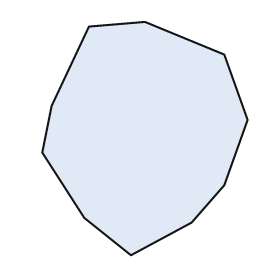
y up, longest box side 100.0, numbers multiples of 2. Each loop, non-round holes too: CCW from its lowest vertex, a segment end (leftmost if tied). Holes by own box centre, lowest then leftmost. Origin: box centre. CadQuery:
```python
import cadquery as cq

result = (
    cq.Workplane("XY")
    .moveTo(-6.0, -50.0)
    .lineTo(20.0, -36.0)
    .lineTo(34.0, -20.0)
    .lineTo(44.0, 8.0)
    .lineTo(34.0, 36.0)
    .lineTo(0.0, 50.0)
    .lineTo(-24.0, 48.0)
    .lineTo(-40.0, 14.0)
    .lineTo(-44.0, -6.0)
    .lineTo(-26.0, -34.0)
    .close()
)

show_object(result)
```